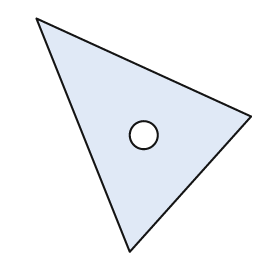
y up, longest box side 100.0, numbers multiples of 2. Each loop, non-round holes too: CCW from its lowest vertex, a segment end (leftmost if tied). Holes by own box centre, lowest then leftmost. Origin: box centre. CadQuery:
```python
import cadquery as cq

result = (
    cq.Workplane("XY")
    .moveTo(-6.0, -50.0)
    .lineTo(46.0, 8.0)
    .lineTo(-46.0, 50.0)
    .close()
    .moveTo(0.0, 0.0)
    .circle(6.0)
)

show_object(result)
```